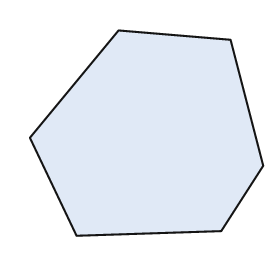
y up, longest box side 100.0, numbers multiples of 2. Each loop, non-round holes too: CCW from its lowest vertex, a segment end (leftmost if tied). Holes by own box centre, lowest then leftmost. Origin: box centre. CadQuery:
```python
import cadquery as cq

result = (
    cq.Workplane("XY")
    .moveTo(-30.0, -44.0)
    .lineTo(32.0, -42.0)
    .lineTo(50.0, -14.0)
    .lineTo(36.0, 40.0)
    .lineTo(-12.0, 44.0)
    .lineTo(-50.0, -2.0)
    .close()
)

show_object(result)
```